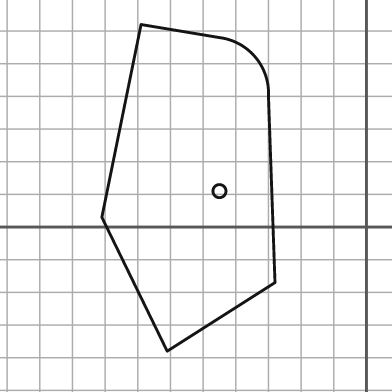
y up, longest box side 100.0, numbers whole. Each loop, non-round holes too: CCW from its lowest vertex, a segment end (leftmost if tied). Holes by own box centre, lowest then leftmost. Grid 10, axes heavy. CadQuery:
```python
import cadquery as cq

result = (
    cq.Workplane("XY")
    .moveTo(-61.0, -38.0)
    .lineTo(-28.0, -17.0)
    .lineTo(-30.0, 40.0)
    .threePointArc((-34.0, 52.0), (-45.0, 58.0))
    .lineTo(-69.0, 62.0)
    .lineTo(-81.0, 3.0)
    .close()
    .moveTo(-45.0, 11.0)
    .circle(2.0)
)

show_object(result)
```